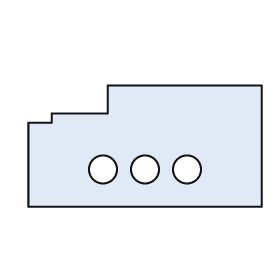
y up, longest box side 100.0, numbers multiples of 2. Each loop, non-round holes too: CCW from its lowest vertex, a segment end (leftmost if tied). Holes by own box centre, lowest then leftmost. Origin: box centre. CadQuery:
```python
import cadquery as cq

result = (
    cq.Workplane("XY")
    .moveTo(-50.0, -26.0)
    .lineTo(50.0, -26.0)
    .lineTo(50.0, 26.0)
    .lineTo(-16.0, 26.0)
    .lineTo(-16.0, 14.0)
    .lineTo(-40.0, 14.0)
    .lineTo(-40.0, 10.0)
    .lineTo(-50.0, 10.0)
    .close()
    .moveTo(-18.0, -10.0)
    .circle(6.0)
    .moveTo(0.0, -10.0)
    .circle(6.0)
    .moveTo(18.0, -10.0)
    .circle(6.0)
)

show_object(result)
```